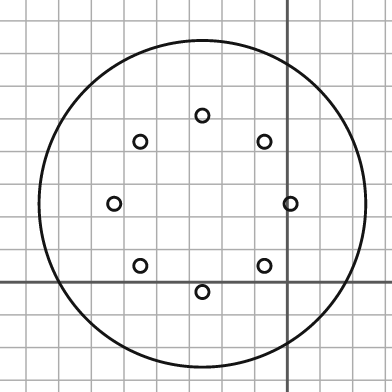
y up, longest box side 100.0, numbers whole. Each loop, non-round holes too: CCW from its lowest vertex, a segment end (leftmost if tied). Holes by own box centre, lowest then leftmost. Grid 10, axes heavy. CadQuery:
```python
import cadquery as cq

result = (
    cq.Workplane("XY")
    .moveTo(-26.0, 24.0)
    .circle(50.0)
    .moveTo(-26.0, -3.0)
    .circle(2.0)
    .moveTo(-45.0, 5.0)
    .circle(2.0)
    .moveTo(-7.0, 5.0)
    .circle(2.0)
    .moveTo(-53.0, 24.0)
    .circle(2.0)
    .moveTo(1.0, 24.0)
    .circle(2.0)
    .moveTo(-45.0, 43.0)
    .circle(2.0)
    .moveTo(-7.0, 43.0)
    .circle(2.0)
    .moveTo(-26.0, 51.0)
    .circle(2.0)
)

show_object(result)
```